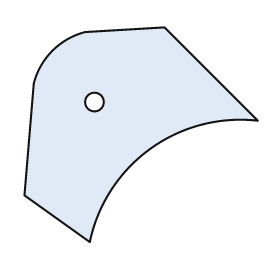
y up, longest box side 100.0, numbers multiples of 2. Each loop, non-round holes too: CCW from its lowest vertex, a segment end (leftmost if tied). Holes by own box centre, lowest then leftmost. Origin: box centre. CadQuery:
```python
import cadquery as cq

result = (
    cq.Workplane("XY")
    .moveTo(-22.0, -46.0)
    .threePointArc((4.0, -6.0), (50.0, 6.0))
    .lineTo(10.0, 46.0)
    .lineTo(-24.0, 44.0)
    .threePointArc((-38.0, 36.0), (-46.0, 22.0))
    .lineTo(-50.0, -26.0)
    .close()
    .moveTo(-20.0, 14.0)
    .circle(4.0)
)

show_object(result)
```